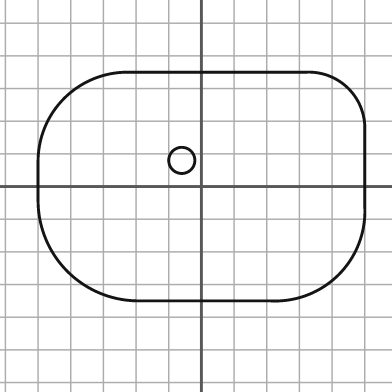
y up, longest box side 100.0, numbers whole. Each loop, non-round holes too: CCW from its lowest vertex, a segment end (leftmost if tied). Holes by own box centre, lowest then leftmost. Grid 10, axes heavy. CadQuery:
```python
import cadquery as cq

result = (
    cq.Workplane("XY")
    .moveTo(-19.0, -35.0)
    .lineTo(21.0, -35.0)
    .threePointArc((42.0, -27.0), (50.0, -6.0))
    .lineTo(50.0, 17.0)
    .threePointArc((45.0, 30.0), (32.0, 35.0))
    .lineTo(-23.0, 35.0)
    .threePointArc((-42.0, 27.0), (-50.0, 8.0))
    .lineTo(-50.0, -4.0)
    .threePointArc((-41.0, -26.0), (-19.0, -35.0))
    .close()
    .moveTo(-6.0, 8.0)
    .circle(4.0)
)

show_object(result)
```